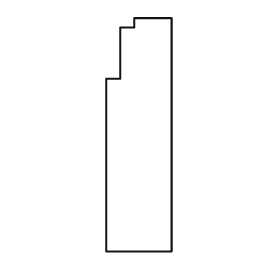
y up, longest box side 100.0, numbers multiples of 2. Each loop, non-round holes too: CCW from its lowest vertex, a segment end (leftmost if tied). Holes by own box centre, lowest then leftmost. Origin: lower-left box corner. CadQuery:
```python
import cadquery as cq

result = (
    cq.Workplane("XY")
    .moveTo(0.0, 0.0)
    .lineTo(28.0, 0.0)
    .lineTo(28.0, 100.0)
    .lineTo(12.0, 100.0)
    .lineTo(12.0, 96.0)
    .lineTo(6.0, 96.0)
    .lineTo(6.0, 74.0)
    .lineTo(0.0, 74.0)
    .close()
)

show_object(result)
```